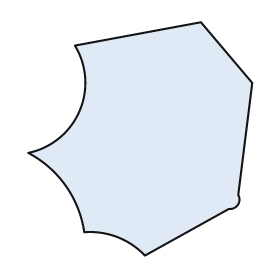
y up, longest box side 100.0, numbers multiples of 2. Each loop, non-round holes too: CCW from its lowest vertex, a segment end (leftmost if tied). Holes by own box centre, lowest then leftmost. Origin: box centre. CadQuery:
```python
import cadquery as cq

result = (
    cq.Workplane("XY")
    .moveTo(2.0, -50.0)
    .lineTo(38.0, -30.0)
    .threePointArc((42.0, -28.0), (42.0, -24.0))
    .lineTo(48.0, 24.0)
    .lineTo(26.0, 50.0)
    .lineTo(-28.0, 40.0)
    .threePointArc((-26.0, 12.0), (-48.0, -6.0))
    .threePointArc((-32.0, -20.0), (-24.0, -40.0))
    .threePointArc((-10.0, -42.0), (2.0, -50.0))
    .close()
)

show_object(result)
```